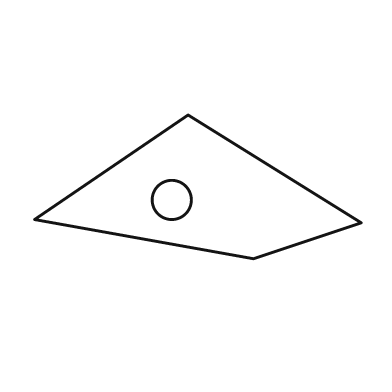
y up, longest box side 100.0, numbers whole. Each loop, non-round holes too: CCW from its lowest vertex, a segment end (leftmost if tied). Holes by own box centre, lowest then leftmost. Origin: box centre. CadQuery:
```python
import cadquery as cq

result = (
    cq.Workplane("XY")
    .moveTo(17.0, -22.0)
    .lineTo(50.0, -11.0)
    .lineTo(-3.0, 22.0)
    .lineTo(-50.0, -10.0)
    .close()
    .moveTo(-8.0, -4.0)
    .circle(6.0)
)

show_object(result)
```